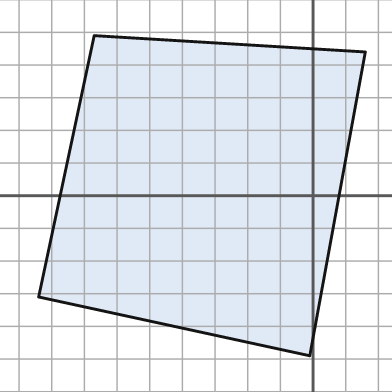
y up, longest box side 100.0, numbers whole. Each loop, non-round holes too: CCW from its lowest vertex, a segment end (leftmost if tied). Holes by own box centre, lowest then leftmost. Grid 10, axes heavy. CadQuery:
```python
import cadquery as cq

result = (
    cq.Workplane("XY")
    .moveTo(-1.0, -49.0)
    .lineTo(16.0, 44.0)
    .lineTo(-67.0, 49.0)
    .lineTo(-84.0, -31.0)
    .close()
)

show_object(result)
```